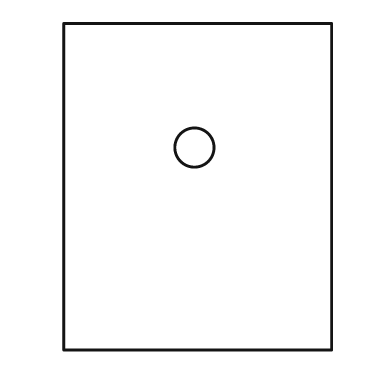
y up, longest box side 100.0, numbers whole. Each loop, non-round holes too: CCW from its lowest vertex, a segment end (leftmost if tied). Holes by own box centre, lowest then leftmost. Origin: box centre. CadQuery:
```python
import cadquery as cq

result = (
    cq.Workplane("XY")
    .moveTo(-41.0, -50.0)
    .lineTo(41.0, -50.0)
    .lineTo(41.0, 50.0)
    .lineTo(-41.0, 50.0)
    .close()
    .moveTo(-1.0, 12.0)
    .circle(6.0)
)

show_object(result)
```